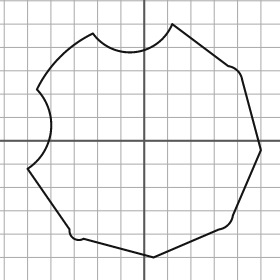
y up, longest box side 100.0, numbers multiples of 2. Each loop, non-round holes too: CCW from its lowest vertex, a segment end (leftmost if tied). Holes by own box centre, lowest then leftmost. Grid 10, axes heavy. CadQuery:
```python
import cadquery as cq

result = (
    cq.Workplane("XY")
    .moveTo(4.0, -50.0)
    .lineTo(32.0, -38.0)
    .threePointArc((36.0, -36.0), (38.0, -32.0))
    .lineTo(50.0, -4.0)
    .lineTo(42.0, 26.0)
    .threePointArc((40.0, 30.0), (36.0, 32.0))
    .lineTo(12.0, 50.0)
    .threePointArc((-4.0, 38.0), (-22.0, 46.0))
    .threePointArc((-36.0, 36.0), (-46.0, 22.0))
    .threePointArc((-40.0, 4.0), (-50.0, -12.0))
    .lineTo(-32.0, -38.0)
    .threePointArc((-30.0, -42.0), (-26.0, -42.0))
    .close()
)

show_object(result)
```